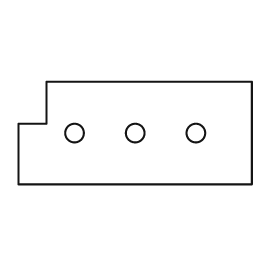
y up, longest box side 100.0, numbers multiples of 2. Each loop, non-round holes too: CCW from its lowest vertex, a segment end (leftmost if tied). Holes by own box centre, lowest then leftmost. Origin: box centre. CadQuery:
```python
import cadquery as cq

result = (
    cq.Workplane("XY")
    .moveTo(-50.0, -22.0)
    .lineTo(50.0, -22.0)
    .lineTo(50.0, 22.0)
    .lineTo(-38.0, 22.0)
    .lineTo(-38.0, 4.0)
    .lineTo(-50.0, 4.0)
    .close()
    .moveTo(-26.0, 0.0)
    .circle(4.0)
    .moveTo(0.0, 0.0)
    .circle(4.0)
    .moveTo(26.0, 0.0)
    .circle(4.0)
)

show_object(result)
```